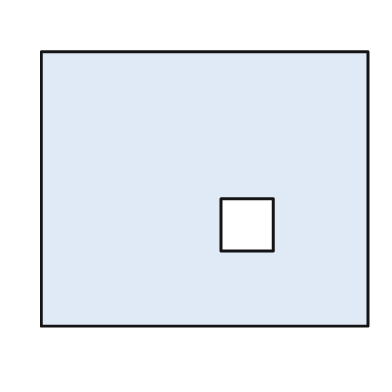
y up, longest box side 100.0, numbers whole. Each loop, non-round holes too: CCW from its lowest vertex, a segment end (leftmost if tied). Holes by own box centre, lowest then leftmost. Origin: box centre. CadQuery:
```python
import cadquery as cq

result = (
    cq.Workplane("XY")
    .moveTo(-50.0, -42.0)
    .lineTo(50.0, -42.0)
    .lineTo(50.0, 42.0)
    .lineTo(-50.0, 42.0)
    .close()
    .moveTo(5.0, -19.0)
    .lineTo(21.0, -19.0)
    .lineTo(21.0, -3.0)
    .lineTo(5.0, -3.0)
    .close()
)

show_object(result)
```